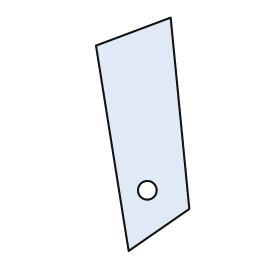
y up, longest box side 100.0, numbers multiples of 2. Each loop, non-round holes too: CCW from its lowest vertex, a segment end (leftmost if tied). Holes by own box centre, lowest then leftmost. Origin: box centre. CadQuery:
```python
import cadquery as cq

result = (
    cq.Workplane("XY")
    .moveTo(-6.0, -50.0)
    .lineTo(20.0, -32.0)
    .lineTo(12.0, 50.0)
    .lineTo(-20.0, 38.0)
    .close()
    .moveTo(2.0, -24.0)
    .circle(4.0)
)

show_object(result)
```